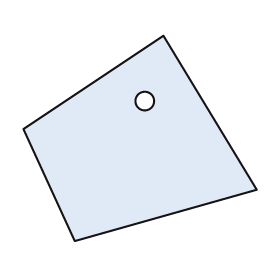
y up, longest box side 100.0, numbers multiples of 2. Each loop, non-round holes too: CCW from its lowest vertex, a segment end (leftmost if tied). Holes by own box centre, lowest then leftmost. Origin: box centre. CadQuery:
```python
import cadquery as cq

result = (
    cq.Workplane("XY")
    .moveTo(-28.0, -44.0)
    .lineTo(50.0, -22.0)
    .lineTo(10.0, 44.0)
    .lineTo(-50.0, 4.0)
    .close()
    .moveTo(2.0, 16.0)
    .circle(4.0)
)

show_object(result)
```